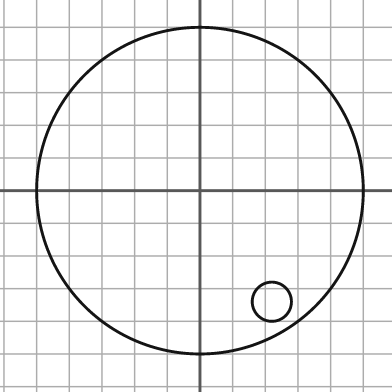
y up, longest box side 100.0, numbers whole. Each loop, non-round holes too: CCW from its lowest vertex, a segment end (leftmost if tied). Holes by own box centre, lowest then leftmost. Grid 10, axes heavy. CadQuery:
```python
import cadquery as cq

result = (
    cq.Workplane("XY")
    .moveTo(0.0, 0.0)
    .circle(50.0)
    .moveTo(22.0, -34.0)
    .circle(6.0)
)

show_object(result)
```